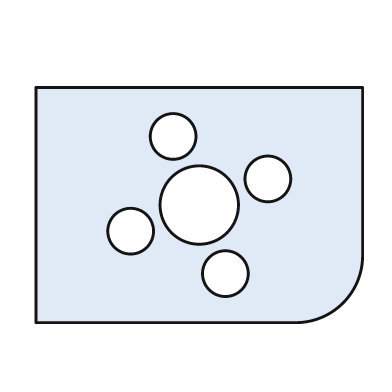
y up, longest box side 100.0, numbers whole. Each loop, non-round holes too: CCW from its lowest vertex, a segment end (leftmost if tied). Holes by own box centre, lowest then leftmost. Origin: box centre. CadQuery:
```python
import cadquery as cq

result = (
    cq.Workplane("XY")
    .moveTo(-50.0, -36.0)
    .lineTo(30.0, -36.0)
    .threePointArc((44.0, -30.0), (50.0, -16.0))
    .lineTo(50.0, 36.0)
    .lineTo(-50.0, 36.0)
    .close()
    .moveTo(8.0, -21.0)
    .circle(7.0)
    .moveTo(-21.0, -8.0)
    .circle(7.0)
    .moveTo(0.0, 0.0)
    .circle(12.0)
    .moveTo(21.0, 8.0)
    .circle(7.0)
    .moveTo(-8.0, 21.0)
    .circle(7.0)
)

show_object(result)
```